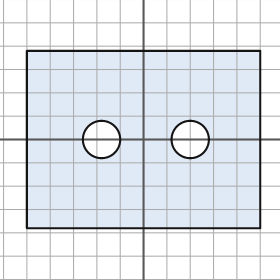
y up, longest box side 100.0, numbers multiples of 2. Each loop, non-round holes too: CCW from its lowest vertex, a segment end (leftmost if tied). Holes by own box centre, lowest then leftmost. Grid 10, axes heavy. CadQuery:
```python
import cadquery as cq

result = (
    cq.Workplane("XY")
    .moveTo(-50.0, -38.0)
    .lineTo(50.0, -38.0)
    .lineTo(50.0, 38.0)
    .lineTo(-50.0, 38.0)
    .close()
    .moveTo(-18.0, 0.0)
    .circle(8.0)
    .moveTo(20.0, 0.0)
    .circle(8.0)
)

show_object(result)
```